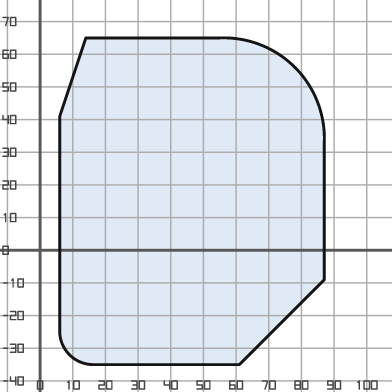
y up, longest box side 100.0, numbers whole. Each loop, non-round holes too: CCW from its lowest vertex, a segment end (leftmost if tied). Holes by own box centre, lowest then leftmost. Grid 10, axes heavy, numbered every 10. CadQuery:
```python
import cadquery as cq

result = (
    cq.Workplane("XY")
    .moveTo(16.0, -35.0)
    .lineTo(61.0, -35.0)
    .lineTo(87.0, -9.0)
    .lineTo(87.0, 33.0)
    .threePointArc((78.0, 56.0), (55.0, 65.0))
    .lineTo(14.0, 65.0)
    .lineTo(6.0, 41.0)
    .lineTo(6.0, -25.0)
    .threePointArc((9.0, -32.0), (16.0, -35.0))
    .close()
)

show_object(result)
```